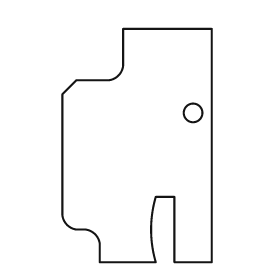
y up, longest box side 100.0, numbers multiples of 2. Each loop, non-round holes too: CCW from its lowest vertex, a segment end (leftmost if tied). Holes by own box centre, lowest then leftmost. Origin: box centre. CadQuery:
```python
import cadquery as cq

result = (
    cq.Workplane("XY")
    .moveTo(-16.0, -50.0)
    .lineTo(8.0, -50.0)
    .threePointArc((6.0, -36.0), (8.0, -22.0))
    .lineTo(16.0, -22.0)
    .lineTo(16.0, -50.0)
    .lineTo(32.0, -50.0)
    .lineTo(32.0, 50.0)
    .lineTo(-6.0, 50.0)
    .lineTo(-6.0, 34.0)
    .threePointArc((-8.0, 30.0), (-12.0, 28.0))
    .lineTo(-26.0, 28.0)
    .lineTo(-32.0, 22.0)
    .lineTo(-32.0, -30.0)
    .threePointArc((-30.0, -34.0), (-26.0, -36.0))
    .lineTo(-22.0, -36.0)
    .threePointArc((-18.0, -38.0), (-16.0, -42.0))
    .close()
    .moveTo(24.0, 14.0)
    .circle(4.0)
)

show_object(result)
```